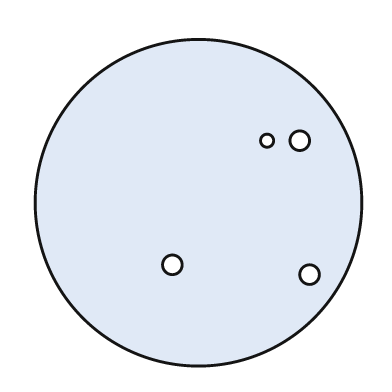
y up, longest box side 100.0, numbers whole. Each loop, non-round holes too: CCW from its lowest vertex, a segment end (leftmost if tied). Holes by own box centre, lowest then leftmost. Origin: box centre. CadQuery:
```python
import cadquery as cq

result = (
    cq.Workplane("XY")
    .moveTo(0.0, 0.0)
    .circle(50.0)
    .moveTo(34.0, -22.0)
    .circle(3.0)
    .moveTo(-8.0, -19.0)
    .circle(3.0)
    .moveTo(21.0, 19.0)
    .circle(2.0)
    .moveTo(31.0, 19.0)
    .circle(3.0)
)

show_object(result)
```